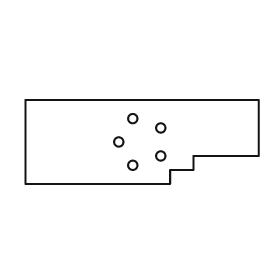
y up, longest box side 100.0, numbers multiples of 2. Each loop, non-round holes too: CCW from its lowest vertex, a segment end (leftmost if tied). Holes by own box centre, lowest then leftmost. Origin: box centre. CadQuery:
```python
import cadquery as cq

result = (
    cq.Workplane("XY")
    .moveTo(-50.0, -18.0)
    .lineTo(12.0, -18.0)
    .lineTo(12.0, -12.0)
    .lineTo(22.0, -12.0)
    .lineTo(22.0, -6.0)
    .lineTo(50.0, -6.0)
    .lineTo(50.0, 18.0)
    .lineTo(-50.0, 18.0)
    .close()
    .moveTo(-4.0, -10.0)
    .circle(2.0)
    .moveTo(8.0, -6.0)
    .circle(2.0)
    .moveTo(-10.0, 0.0)
    .circle(2.0)
    .moveTo(8.0, 6.0)
    .circle(2.0)
    .moveTo(-4.0, 10.0)
    .circle(2.0)
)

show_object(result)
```